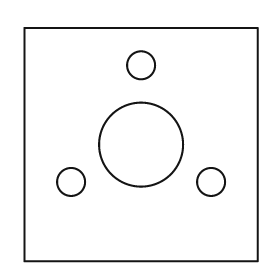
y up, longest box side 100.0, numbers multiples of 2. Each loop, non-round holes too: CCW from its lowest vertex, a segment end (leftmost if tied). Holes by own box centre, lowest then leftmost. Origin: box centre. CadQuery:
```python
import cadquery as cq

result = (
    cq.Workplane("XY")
    .moveTo(-50.0, -50.0)
    .lineTo(50.0, -50.0)
    .lineTo(50.0, 50.0)
    .lineTo(-50.0, 50.0)
    .close()
    .moveTo(-30.0, -16.0)
    .circle(6.0)
    .moveTo(30.0, -16.0)
    .circle(6.0)
    .moveTo(0.0, 0.0)
    .circle(18.0)
    .moveTo(0.0, 34.0)
    .circle(6.0)
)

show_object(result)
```